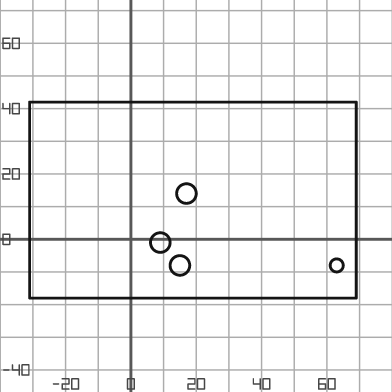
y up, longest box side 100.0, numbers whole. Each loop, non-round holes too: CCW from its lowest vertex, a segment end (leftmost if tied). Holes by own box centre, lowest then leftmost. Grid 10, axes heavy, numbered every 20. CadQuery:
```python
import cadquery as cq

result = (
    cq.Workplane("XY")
    .moveTo(-31.0, -18.0)
    .lineTo(69.0, -18.0)
    .lineTo(69.0, 42.0)
    .lineTo(-31.0, 42.0)
    .close()
    .moveTo(15.0, -8.0)
    .circle(3.0)
    .moveTo(63.0, -8.0)
    .circle(2.0)
    .moveTo(9.0, -1.0)
    .circle(3.0)
    .moveTo(17.0, 14.0)
    .circle(3.0)
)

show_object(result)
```